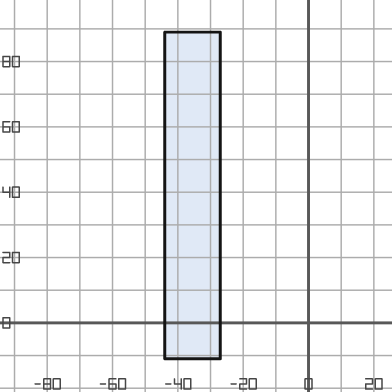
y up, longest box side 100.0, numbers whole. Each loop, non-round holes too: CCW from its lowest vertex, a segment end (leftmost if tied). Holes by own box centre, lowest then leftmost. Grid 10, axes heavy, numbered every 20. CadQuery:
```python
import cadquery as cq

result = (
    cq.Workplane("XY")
    .moveTo(-44.0, -11.0)
    .lineTo(-27.0, -11.0)
    .lineTo(-27.0, 89.0)
    .lineTo(-44.0, 89.0)
    .close()
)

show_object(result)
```